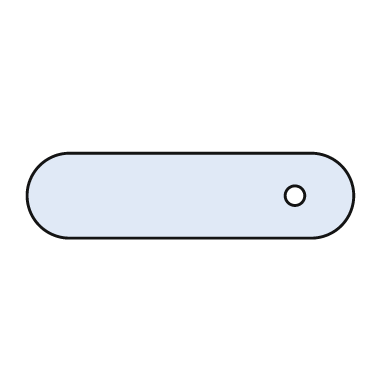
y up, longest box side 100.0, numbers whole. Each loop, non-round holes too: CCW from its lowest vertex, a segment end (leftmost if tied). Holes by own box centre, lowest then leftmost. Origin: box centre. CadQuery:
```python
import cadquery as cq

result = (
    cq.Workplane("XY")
    .moveTo(-37.0, -13.0)
    .lineTo(37.0, -13.0)
    .threePointArc((50.0, 0.0), (37.0, 13.0))
    .lineTo(-37.0, 13.0)
    .threePointArc((-50.0, 0.0), (-37.0, -13.0))
    .close()
    .moveTo(32.0, 0.0)
    .circle(3.0)
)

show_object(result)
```